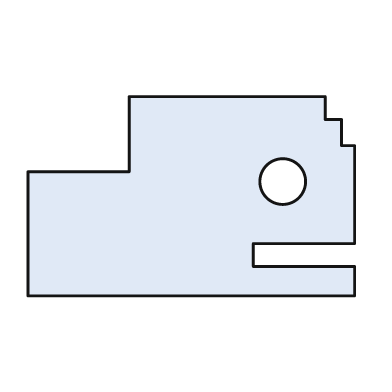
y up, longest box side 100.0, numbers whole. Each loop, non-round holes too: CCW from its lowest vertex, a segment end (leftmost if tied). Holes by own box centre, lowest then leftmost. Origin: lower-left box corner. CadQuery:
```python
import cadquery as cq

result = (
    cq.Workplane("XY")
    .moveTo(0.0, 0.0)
    .lineTo(100.0, 0.0)
    .lineTo(100.0, 9.0)
    .lineTo(69.0, 9.0)
    .lineTo(69.0, 16.0)
    .lineTo(100.0, 16.0)
    .lineTo(100.0, 46.0)
    .lineTo(96.0, 46.0)
    .lineTo(96.0, 54.0)
    .lineTo(91.0, 54.0)
    .lineTo(91.0, 61.0)
    .lineTo(31.0, 61.0)
    .lineTo(31.0, 38.0)
    .lineTo(0.0, 38.0)
    .close()
    .moveTo(78.0, 35.0)
    .circle(7.0)
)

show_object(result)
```